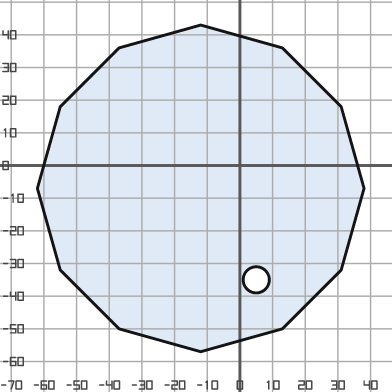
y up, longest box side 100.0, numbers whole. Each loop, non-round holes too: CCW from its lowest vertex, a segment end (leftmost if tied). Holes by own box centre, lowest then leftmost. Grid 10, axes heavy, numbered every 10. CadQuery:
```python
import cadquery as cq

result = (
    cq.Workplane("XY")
    .moveTo(-12.0, -57.0)
    .lineTo(13.0, -50.0)
    .lineTo(31.0, -32.0)
    .lineTo(38.0, -7.0)
    .lineTo(31.0, 18.0)
    .lineTo(13.0, 36.0)
    .lineTo(-12.0, 43.0)
    .lineTo(-37.0, 36.0)
    .lineTo(-55.0, 18.0)
    .lineTo(-62.0, -7.0)
    .lineTo(-55.0, -32.0)
    .lineTo(-37.0, -50.0)
    .close()
    .moveTo(5.0, -35.0)
    .circle(4.0)
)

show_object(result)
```